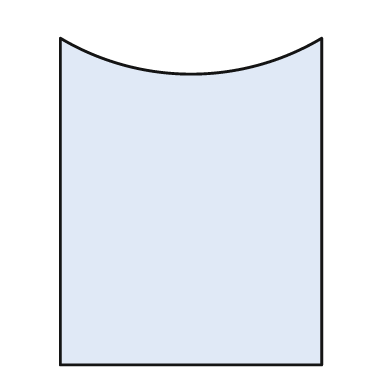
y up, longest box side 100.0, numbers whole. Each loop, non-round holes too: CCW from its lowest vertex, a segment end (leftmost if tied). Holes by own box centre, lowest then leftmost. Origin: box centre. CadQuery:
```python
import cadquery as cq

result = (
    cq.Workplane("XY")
    .moveTo(-40.0, -50.0)
    .lineTo(40.0, -50.0)
    .lineTo(40.0, 50.0)
    .threePointArc((0.0, 39.0), (-40.0, 50.0))
    .close()
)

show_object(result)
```